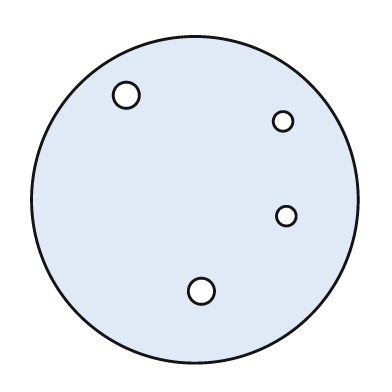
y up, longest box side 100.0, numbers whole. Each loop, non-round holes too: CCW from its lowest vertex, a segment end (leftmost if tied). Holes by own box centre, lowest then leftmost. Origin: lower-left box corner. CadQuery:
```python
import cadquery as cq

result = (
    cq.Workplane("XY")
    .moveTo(50.0, 50.0)
    .circle(50.0)
    .moveTo(52.0, 22.0)
    .circle(4.0)
    .moveTo(78.0, 45.0)
    .circle(3.0)
    .moveTo(77.0, 74.0)
    .circle(3.0)
    .moveTo(29.0, 82.0)
    .circle(4.0)
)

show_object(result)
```